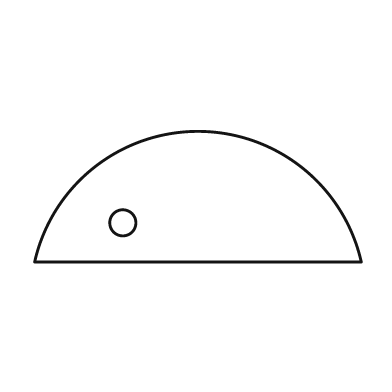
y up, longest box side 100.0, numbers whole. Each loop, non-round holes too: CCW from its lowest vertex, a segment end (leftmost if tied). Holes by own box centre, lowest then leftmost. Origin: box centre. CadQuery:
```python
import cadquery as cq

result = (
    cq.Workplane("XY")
    .moveTo(-50.0, -20.0)
    .lineTo(50.0, -20.0)
    .threePointArc((0.0, 20.0), (-50.0, -20.0))
    .close()
    .moveTo(-23.0, -8.0)
    .circle(4.0)
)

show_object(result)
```